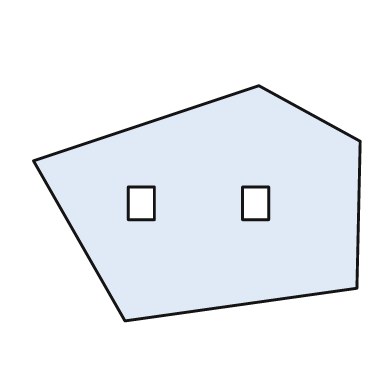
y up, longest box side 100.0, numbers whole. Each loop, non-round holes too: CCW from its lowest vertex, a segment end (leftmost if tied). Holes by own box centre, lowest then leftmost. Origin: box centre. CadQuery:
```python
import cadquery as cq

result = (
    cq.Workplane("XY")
    .moveTo(-22.0, -36.0)
    .lineTo(49.0, -26.0)
    .lineTo(50.0, 19.0)
    .lineTo(19.0, 36.0)
    .lineTo(-50.0, 13.0)
    .close()
    .moveTo(-21.0, -5.0)
    .lineTo(-13.0, -5.0)
    .lineTo(-13.0, 5.0)
    .lineTo(-21.0, 5.0)
    .close()
    .moveTo(14.0, -5.0)
    .lineTo(22.0, -5.0)
    .lineTo(22.0, 5.0)
    .lineTo(14.0, 5.0)
    .close()
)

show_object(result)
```